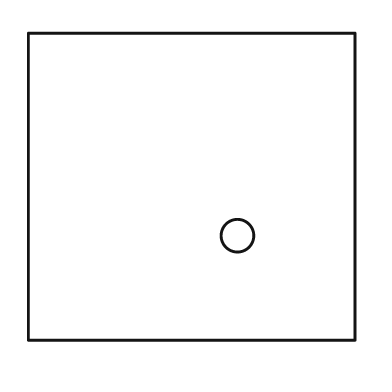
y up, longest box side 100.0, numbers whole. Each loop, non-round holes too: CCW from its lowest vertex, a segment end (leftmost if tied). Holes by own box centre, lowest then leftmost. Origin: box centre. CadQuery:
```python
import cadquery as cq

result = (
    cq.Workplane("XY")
    .moveTo(-50.0, -47.0)
    .lineTo(50.0, -47.0)
    .lineTo(50.0, 47.0)
    .lineTo(-50.0, 47.0)
    .close()
    .moveTo(14.0, -15.0)
    .circle(5.0)
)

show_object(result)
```